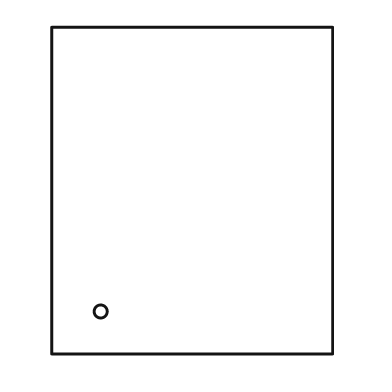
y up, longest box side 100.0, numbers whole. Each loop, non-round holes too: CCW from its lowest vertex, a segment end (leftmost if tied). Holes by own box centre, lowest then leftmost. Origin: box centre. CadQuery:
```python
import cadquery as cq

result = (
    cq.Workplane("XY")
    .moveTo(-43.0, -50.0)
    .lineTo(43.0, -50.0)
    .lineTo(43.0, 50.0)
    .lineTo(-43.0, 50.0)
    .close()
    .moveTo(-28.0, -37.0)
    .circle(2.0)
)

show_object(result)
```